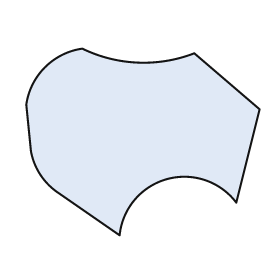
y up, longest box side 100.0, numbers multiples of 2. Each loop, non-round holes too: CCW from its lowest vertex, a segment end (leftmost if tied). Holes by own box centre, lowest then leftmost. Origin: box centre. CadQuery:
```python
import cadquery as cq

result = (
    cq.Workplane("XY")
    .moveTo(-10.0, -40.0)
    .threePointArc((10.0, -16.0), (40.0, -26.0))
    .lineTo(50.0, 14.0)
    .lineTo(22.0, 38.0)
    .threePointArc((-2.0, 34.0), (-26.0, 40.0))
    .threePointArc((-42.0, 32.0), (-50.0, 16.0))
    .lineTo(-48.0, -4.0)
    .threePointArc((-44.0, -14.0), (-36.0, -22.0))
    .close()
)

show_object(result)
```